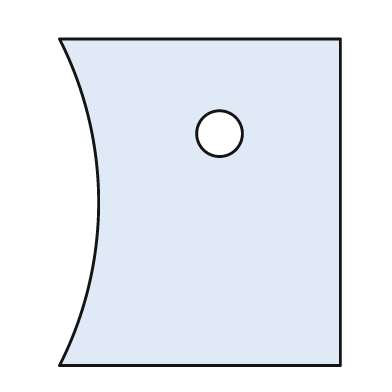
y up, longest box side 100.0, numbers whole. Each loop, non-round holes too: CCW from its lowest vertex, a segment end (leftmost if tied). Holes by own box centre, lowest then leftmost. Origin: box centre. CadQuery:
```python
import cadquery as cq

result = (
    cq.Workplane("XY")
    .moveTo(-43.0, -50.0)
    .lineTo(43.0, -50.0)
    .lineTo(43.0, 50.0)
    .lineTo(-43.0, 50.0)
    .threePointArc((-31.0, 0.0), (-43.0, -50.0))
    .close()
    .moveTo(6.0, 21.0)
    .circle(7.0)
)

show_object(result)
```